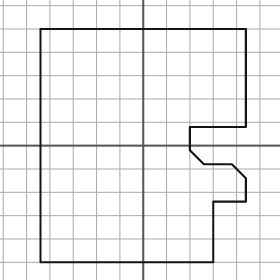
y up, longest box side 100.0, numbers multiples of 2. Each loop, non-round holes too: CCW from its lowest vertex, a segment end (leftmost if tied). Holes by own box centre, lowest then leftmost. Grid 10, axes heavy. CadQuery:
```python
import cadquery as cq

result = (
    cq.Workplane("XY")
    .moveTo(-44.0, -50.0)
    .lineTo(30.0, -50.0)
    .lineTo(30.0, -24.0)
    .lineTo(44.0, -24.0)
    .lineTo(44.0, -14.0)
    .lineTo(38.0, -8.0)
    .lineTo(26.0, -8.0)
    .lineTo(20.0, -2.0)
    .lineTo(20.0, 8.0)
    .lineTo(44.0, 8.0)
    .lineTo(44.0, 50.0)
    .lineTo(-44.0, 50.0)
    .close()
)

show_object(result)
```